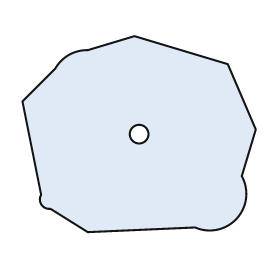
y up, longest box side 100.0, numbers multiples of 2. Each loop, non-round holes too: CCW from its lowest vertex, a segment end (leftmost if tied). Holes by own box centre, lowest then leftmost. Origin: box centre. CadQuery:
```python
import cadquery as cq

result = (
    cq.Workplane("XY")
    .moveTo(-22.0, -42.0)
    .lineTo(24.0, -40.0)
    .threePointArc((42.0, -36.0), (44.0, -18.0))
    .lineTo(50.0, 2.0)
    .lineTo(38.0, 30.0)
    .lineTo(-2.0, 42.0)
    .lineTo(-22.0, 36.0)
    .threePointArc((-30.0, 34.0), (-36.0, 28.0))
    .lineTo(-50.0, 14.0)
    .lineTo(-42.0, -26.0)
    .threePointArc((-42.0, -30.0), (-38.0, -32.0))
    .close()
    .moveTo(0.0, 0.0)
    .circle(4.0)
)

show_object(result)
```